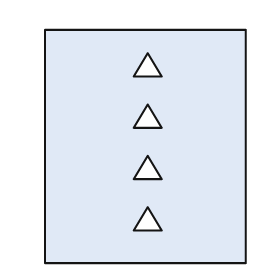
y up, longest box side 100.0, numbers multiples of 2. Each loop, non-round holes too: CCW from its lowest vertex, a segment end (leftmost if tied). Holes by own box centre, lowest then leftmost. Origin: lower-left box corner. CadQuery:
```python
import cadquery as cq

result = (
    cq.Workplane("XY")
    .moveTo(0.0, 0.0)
    .lineTo(86.0, 0.0)
    .lineTo(86.0, 100.0)
    .lineTo(0.0, 100.0)
    .close()
    .moveTo(38.0, 14.0)
    .lineTo(50.0, 14.0)
    .lineTo(44.0, 24.0)
    .close()
    .moveTo(38.0, 36.0)
    .lineTo(50.0, 36.0)
    .lineTo(44.0, 46.0)
    .close()
    .moveTo(38.0, 58.0)
    .lineTo(50.0, 58.0)
    .lineTo(44.0, 68.0)
    .close()
    .moveTo(38.0, 80.0)
    .lineTo(50.0, 80.0)
    .lineTo(44.0, 90.0)
    .close()
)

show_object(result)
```